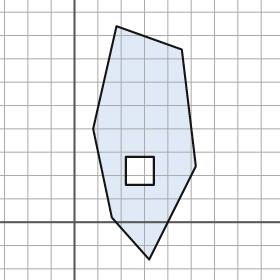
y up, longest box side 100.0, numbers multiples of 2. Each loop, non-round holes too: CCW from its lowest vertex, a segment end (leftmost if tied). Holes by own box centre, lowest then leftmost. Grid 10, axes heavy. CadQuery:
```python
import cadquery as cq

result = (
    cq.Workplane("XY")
    .moveTo(32.0, -16.0)
    .lineTo(52.0, 24.0)
    .lineTo(46.0, 74.0)
    .lineTo(18.0, 84.0)
    .lineTo(8.0, 40.0)
    .lineTo(16.0, 2.0)
    .close()
    .moveTo(22.0, 16.0)
    .lineTo(34.0, 16.0)
    .lineTo(34.0, 28.0)
    .lineTo(22.0, 28.0)
    .close()
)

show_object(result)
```